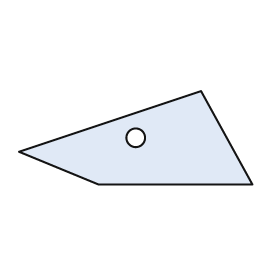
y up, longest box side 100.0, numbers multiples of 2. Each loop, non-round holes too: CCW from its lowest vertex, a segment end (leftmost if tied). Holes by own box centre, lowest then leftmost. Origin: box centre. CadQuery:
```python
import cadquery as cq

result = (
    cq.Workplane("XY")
    .moveTo(-16.0, -20.0)
    .lineTo(50.0, -20.0)
    .lineTo(28.0, 20.0)
    .lineTo(-50.0, -6.0)
    .close()
    .moveTo(0.0, 0.0)
    .circle(4.0)
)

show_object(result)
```